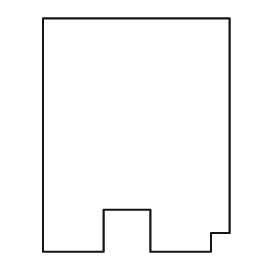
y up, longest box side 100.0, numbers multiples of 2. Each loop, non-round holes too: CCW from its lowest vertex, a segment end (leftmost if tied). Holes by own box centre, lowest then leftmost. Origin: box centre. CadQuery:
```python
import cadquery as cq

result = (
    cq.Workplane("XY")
    .moveTo(-40.0, -50.0)
    .lineTo(-14.0, -50.0)
    .lineTo(-14.0, -32.0)
    .lineTo(6.0, -32.0)
    .lineTo(6.0, -50.0)
    .lineTo(32.0, -50.0)
    .lineTo(32.0, -42.0)
    .lineTo(40.0, -42.0)
    .lineTo(40.0, 50.0)
    .lineTo(-40.0, 50.0)
    .close()
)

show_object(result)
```